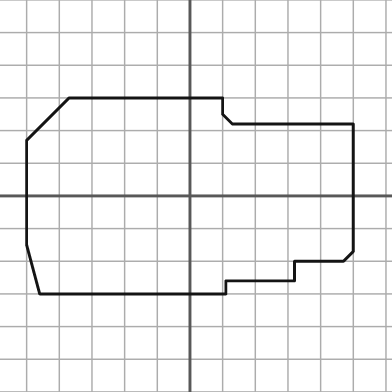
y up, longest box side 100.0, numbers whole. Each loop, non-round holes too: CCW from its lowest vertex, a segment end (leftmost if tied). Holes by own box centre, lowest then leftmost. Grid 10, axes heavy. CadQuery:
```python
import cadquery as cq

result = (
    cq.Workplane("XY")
    .moveTo(-46.0, -30.0)
    .lineTo(11.0, -30.0)
    .lineTo(11.0, -26.0)
    .lineTo(32.0, -26.0)
    .lineTo(32.0, -20.0)
    .lineTo(47.0, -20.0)
    .lineTo(50.0, -17.0)
    .lineTo(50.0, 22.0)
    .lineTo(13.0, 22.0)
    .lineTo(10.0, 25.0)
    .lineTo(10.0, 30.0)
    .lineTo(-37.0, 30.0)
    .lineTo(-50.0, 17.0)
    .lineTo(-50.0, -15.0)
    .close()
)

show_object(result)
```